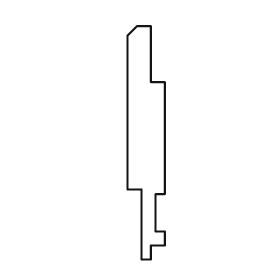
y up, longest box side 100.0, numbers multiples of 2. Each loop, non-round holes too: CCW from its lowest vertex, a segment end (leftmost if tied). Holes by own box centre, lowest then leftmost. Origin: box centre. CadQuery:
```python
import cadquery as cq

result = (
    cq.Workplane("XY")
    .moveTo(-2.0, -50.0)
    .lineTo(2.0, -50.0)
    .lineTo(2.0, -44.0)
    .lineTo(8.0, -44.0)
    .lineTo(8.0, -38.0)
    .lineTo(4.0, -38.0)
    .lineTo(4.0, -22.0)
    .lineTo(8.0, -22.0)
    .lineTo(8.0, 26.0)
    .lineTo(2.0, 26.0)
    .lineTo(2.0, 50.0)
    .lineTo(-4.0, 50.0)
    .lineTo(-8.0, 46.0)
    .lineTo(-8.0, -20.0)
    .lineTo(-2.0, -20.0)
    .close()
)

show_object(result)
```